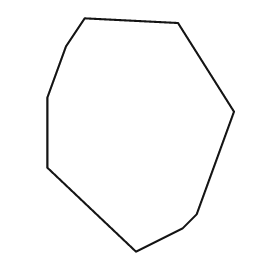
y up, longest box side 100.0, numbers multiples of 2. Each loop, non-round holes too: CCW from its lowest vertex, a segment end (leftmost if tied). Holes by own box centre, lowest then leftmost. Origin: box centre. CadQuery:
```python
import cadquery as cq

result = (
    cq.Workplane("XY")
    .moveTo(-2.0, -50.0)
    .lineTo(18.0, -40.0)
    .lineTo(24.0, -34.0)
    .lineTo(40.0, 10.0)
    .lineTo(16.0, 48.0)
    .lineTo(-24.0, 50.0)
    .lineTo(-32.0, 38.0)
    .lineTo(-40.0, 16.0)
    .lineTo(-40.0, -14.0)
    .close()
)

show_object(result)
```